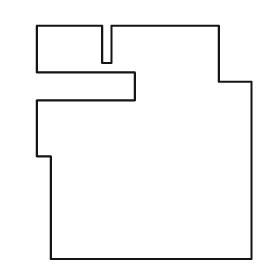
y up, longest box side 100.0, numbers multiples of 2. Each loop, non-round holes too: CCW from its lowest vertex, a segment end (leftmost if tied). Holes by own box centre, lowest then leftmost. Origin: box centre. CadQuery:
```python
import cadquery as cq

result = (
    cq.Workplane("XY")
    .moveTo(-40.0, -50.0)
    .lineTo(46.0, -50.0)
    .lineTo(46.0, 26.0)
    .lineTo(32.0, 26.0)
    .lineTo(32.0, 50.0)
    .lineTo(-14.0, 50.0)
    .lineTo(-14.0, 34.0)
    .lineTo(-18.0, 34.0)
    .lineTo(-18.0, 50.0)
    .lineTo(-46.0, 50.0)
    .lineTo(-46.0, 30.0)
    .lineTo(-4.0, 30.0)
    .lineTo(-4.0, 18.0)
    .lineTo(-46.0, 18.0)
    .lineTo(-46.0, -6.0)
    .lineTo(-40.0, -6.0)
    .close()
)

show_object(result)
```